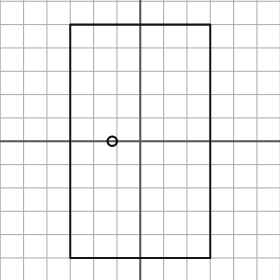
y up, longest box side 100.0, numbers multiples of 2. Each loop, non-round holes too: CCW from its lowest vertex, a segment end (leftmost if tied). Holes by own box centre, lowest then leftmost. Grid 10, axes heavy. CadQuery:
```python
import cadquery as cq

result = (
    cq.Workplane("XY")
    .moveTo(-30.0, -50.0)
    .lineTo(30.0, -50.0)
    .lineTo(30.0, 50.0)
    .lineTo(-30.0, 50.0)
    .close()
    .moveTo(-12.0, 0.0)
    .circle(2.0)
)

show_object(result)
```